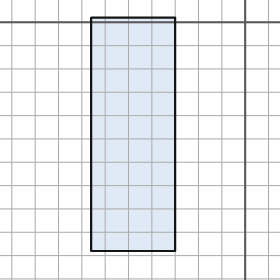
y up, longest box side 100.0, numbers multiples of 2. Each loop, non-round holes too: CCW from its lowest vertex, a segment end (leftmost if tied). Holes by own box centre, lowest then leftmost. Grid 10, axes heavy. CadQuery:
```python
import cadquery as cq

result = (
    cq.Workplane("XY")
    .moveTo(-66.0, -98.0)
    .lineTo(-30.0, -98.0)
    .lineTo(-30.0, 2.0)
    .lineTo(-66.0, 2.0)
    .close()
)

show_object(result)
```